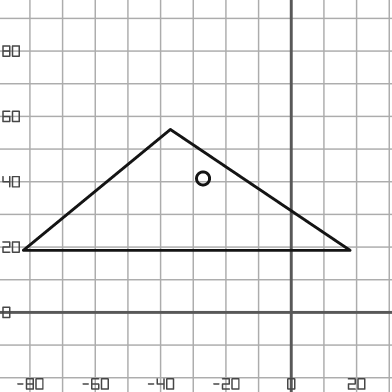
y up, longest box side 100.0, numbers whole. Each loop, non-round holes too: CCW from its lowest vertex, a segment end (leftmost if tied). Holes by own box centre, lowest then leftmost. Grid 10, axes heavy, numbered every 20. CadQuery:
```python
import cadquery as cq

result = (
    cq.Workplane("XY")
    .moveTo(-82.0, 19.0)
    .lineTo(18.0, 19.0)
    .lineTo(-37.0, 56.0)
    .close()
    .moveTo(-27.0, 41.0)
    .circle(2.0)
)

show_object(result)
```